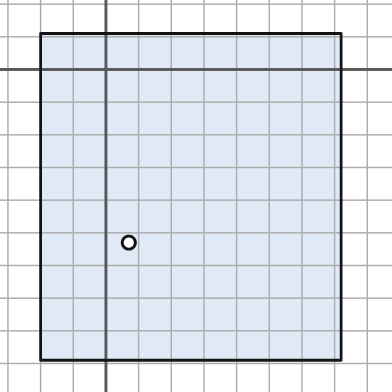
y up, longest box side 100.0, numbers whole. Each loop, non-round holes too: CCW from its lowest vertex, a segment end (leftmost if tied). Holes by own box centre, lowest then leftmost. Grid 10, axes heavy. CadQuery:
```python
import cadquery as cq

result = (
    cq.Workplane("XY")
    .moveTo(-20.0, -89.0)
    .lineTo(72.0, -89.0)
    .lineTo(72.0, 11.0)
    .lineTo(-20.0, 11.0)
    .close()
    .moveTo(7.0, -53.0)
    .circle(2.0)
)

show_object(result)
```